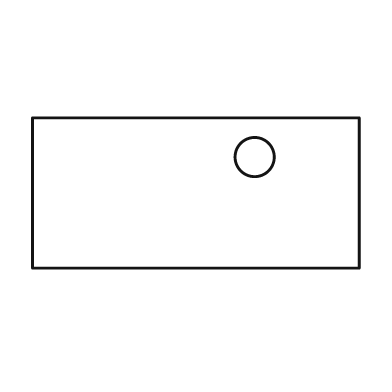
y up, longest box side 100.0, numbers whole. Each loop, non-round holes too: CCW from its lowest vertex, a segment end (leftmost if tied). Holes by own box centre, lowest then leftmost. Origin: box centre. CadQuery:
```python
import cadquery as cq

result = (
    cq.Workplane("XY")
    .moveTo(-50.0, -23.0)
    .lineTo(50.0, -23.0)
    .lineTo(50.0, 23.0)
    .lineTo(-50.0, 23.0)
    .close()
    .moveTo(18.0, 11.0)
    .circle(6.0)
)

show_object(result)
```